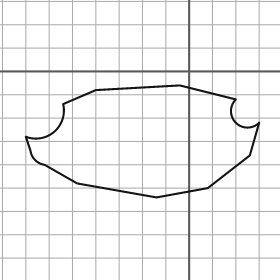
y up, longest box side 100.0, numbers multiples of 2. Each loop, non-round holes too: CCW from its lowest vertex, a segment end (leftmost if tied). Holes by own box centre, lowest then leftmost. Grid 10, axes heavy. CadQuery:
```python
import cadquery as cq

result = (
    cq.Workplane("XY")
    .moveTo(-14.0, -54.0)
    .lineTo(8.0, -50.0)
    .lineTo(26.0, -36.0)
    .lineTo(30.0, -22.0)
    .threePointArc((20.0, -22.0), (20.0, -12.0))
    .lineTo(-4.0, -6.0)
    .lineTo(-40.0, -8.0)
    .lineTo(-54.0, -14.0)
    .threePointArc((-58.0, -26.0), (-70.0, -28.0))
    .lineTo(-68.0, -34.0)
    .threePointArc((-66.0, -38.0), (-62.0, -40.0))
    .lineTo(-48.0, -48.0)
    .close()
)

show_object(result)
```